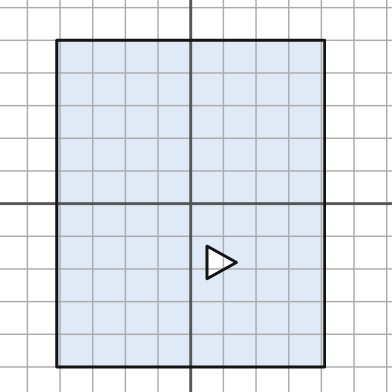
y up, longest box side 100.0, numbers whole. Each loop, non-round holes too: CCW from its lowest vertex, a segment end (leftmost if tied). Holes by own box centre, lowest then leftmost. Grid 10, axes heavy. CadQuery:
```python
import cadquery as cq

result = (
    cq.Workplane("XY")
    .moveTo(-41.0, -50.0)
    .lineTo(41.0, -50.0)
    .lineTo(41.0, 50.0)
    .lineTo(-41.0, 50.0)
    .close()
    .moveTo(5.0, -23.0)
    .lineTo(14.0, -18.0)
    .lineTo(5.0, -13.0)
    .close()
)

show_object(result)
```